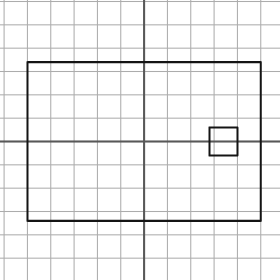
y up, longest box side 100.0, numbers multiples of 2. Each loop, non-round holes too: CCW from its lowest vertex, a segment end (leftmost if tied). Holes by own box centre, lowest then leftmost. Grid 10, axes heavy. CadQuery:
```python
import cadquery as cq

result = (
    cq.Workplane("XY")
    .moveTo(-50.0, -34.0)
    .lineTo(50.0, -34.0)
    .lineTo(50.0, 34.0)
    .lineTo(-50.0, 34.0)
    .close()
    .moveTo(28.0, -6.0)
    .lineTo(40.0, -6.0)
    .lineTo(40.0, 6.0)
    .lineTo(28.0, 6.0)
    .close()
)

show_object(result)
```